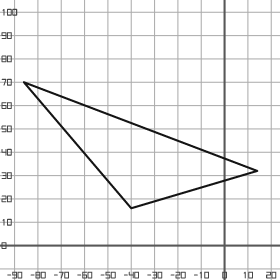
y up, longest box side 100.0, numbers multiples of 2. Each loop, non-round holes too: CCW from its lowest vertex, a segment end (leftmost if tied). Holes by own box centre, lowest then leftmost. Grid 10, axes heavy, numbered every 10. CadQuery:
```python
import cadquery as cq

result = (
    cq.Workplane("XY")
    .moveTo(-40.0, 16.0)
    .lineTo(14.0, 32.0)
    .lineTo(-86.0, 70.0)
    .close()
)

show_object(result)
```